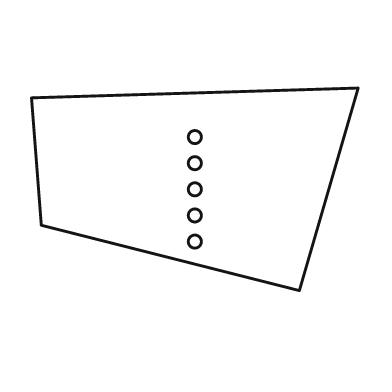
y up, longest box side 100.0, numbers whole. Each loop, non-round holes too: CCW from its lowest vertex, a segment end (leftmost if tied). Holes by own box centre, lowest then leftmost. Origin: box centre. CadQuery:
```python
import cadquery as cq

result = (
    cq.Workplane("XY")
    .moveTo(32.0, -31.0)
    .lineTo(50.0, 31.0)
    .lineTo(-50.0, 28.0)
    .lineTo(-47.0, -11.0)
    .close()
    .moveTo(0.0, -16.0)
    .circle(2.0)
    .moveTo(0.0, -8.0)
    .circle(2.0)
    .moveTo(0.0, 0.0)
    .circle(2.0)
    .moveTo(0.0, 8.0)
    .circle(2.0)
    .moveTo(0.0, 16.0)
    .circle(2.0)
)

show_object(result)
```